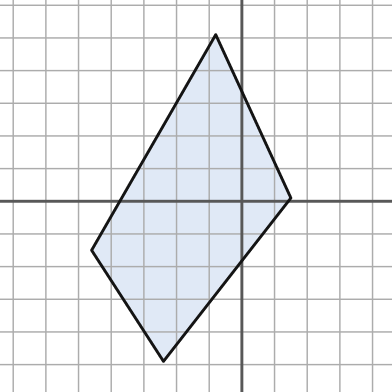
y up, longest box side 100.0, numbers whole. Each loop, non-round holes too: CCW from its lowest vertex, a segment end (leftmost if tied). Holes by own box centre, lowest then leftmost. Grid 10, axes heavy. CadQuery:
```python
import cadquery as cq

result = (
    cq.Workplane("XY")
    .moveTo(-24.0, -49.0)
    .lineTo(15.0, 1.0)
    .lineTo(-8.0, 51.0)
    .lineTo(-46.0, -15.0)
    .close()
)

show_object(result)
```